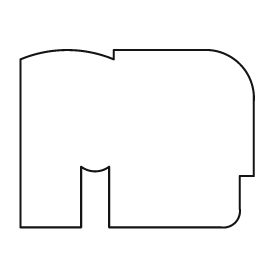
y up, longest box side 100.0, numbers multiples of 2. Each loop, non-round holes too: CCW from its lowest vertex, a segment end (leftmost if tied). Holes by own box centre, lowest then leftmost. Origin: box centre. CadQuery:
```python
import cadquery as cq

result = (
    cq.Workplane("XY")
    .moveTo(-50.0, -38.0)
    .lineTo(-24.0, -38.0)
    .lineTo(-24.0, -12.0)
    .threePointArc((-18.0, -14.0), (-12.0, -12.0))
    .lineTo(-12.0, -38.0)
    .lineTo(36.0, -38.0)
    .threePointArc((42.0, -36.0), (44.0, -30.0))
    .lineTo(44.0, -16.0)
    .lineTo(50.0, -16.0)
    .lineTo(50.0, 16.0)
    .threePointArc((44.0, 32.0), (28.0, 38.0))
    .lineTo(-10.0, 38.0)
    .lineTo(-10.0, 34.0)
    .threePointArc((-30.0, 38.0), (-50.0, 34.0))
    .close()
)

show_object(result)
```